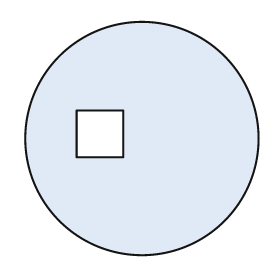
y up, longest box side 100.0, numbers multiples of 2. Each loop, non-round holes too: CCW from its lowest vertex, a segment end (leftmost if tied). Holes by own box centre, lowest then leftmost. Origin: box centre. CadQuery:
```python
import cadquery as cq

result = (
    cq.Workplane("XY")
    .moveTo(0.0, 0.0)
    .circle(50.0)
    .moveTo(-28.0, -8.0)
    .lineTo(-8.0, -8.0)
    .lineTo(-8.0, 12.0)
    .lineTo(-28.0, 12.0)
    .close()
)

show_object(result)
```